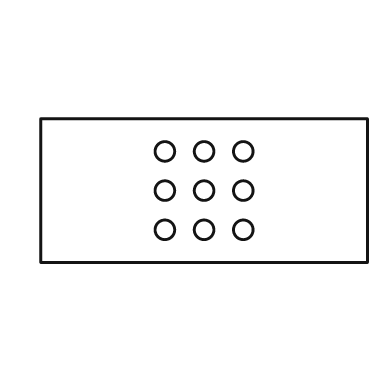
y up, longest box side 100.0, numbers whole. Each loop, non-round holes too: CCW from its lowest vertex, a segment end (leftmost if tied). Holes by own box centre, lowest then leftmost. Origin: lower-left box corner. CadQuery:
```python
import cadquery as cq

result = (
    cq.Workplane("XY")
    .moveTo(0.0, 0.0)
    .lineTo(100.0, 0.0)
    .lineTo(100.0, 44.0)
    .lineTo(0.0, 44.0)
    .close()
    .moveTo(38.0, 10.0)
    .circle(3.0)
    .moveTo(50.0, 10.0)
    .circle(3.0)
    .moveTo(62.0, 10.0)
    .circle(3.0)
    .moveTo(38.0, 22.0)
    .circle(3.0)
    .moveTo(50.0, 22.0)
    .circle(3.0)
    .moveTo(62.0, 22.0)
    .circle(3.0)
    .moveTo(38.0, 34.0)
    .circle(3.0)
    .moveTo(50.0, 34.0)
    .circle(3.0)
    .moveTo(62.0, 34.0)
    .circle(3.0)
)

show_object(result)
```